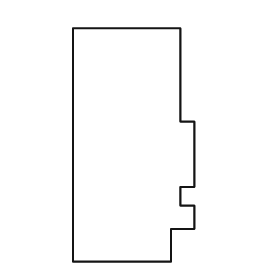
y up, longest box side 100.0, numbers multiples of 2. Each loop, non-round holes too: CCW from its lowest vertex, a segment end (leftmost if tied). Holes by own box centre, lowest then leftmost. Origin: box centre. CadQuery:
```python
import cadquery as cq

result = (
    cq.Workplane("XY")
    .moveTo(-26.0, -50.0)
    .lineTo(16.0, -50.0)
    .lineTo(16.0, -36.0)
    .lineTo(26.0, -36.0)
    .lineTo(26.0, -26.0)
    .lineTo(20.0, -26.0)
    .lineTo(20.0, -18.0)
    .lineTo(26.0, -18.0)
    .lineTo(26.0, 10.0)
    .lineTo(20.0, 10.0)
    .lineTo(20.0, 50.0)
    .lineTo(-26.0, 50.0)
    .close()
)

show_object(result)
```